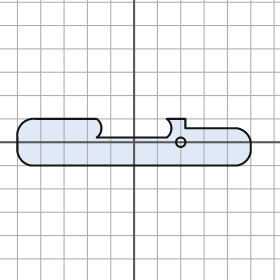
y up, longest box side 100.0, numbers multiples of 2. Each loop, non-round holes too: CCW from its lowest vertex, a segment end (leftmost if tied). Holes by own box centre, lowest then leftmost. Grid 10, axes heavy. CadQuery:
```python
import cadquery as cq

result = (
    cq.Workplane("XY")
    .moveTo(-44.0, -10.0)
    .lineTo(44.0, -10.0)
    .threePointArc((48.0, -8.0), (50.0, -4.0))
    .lineTo(50.0, 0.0)
    .threePointArc((48.0, 4.0), (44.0, 6.0))
    .lineTo(22.0, 6.0)
    .lineTo(22.0, 10.0)
    .lineTo(14.0, 10.0)
    .threePointArc((16.0, 6.0), (14.0, 2.0))
    .lineTo(-16.0, 2.0)
    .threePointArc((-14.0, 6.0), (-16.0, 10.0))
    .lineTo(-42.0, 10.0)
    .threePointArc((-48.0, 8.0), (-50.0, 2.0))
    .lineTo(-50.0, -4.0)
    .threePointArc((-48.0, -8.0), (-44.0, -10.0))
    .close()
    .moveTo(20.0, 0.0)
    .circle(2.0)
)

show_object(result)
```